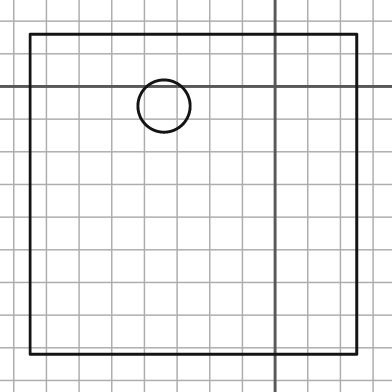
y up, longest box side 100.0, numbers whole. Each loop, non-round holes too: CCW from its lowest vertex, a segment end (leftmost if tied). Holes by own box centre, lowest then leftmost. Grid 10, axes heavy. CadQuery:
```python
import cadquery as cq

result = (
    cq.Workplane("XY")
    .moveTo(-75.0, -82.0)
    .lineTo(25.0, -82.0)
    .lineTo(25.0, 16.0)
    .lineTo(-75.0, 16.0)
    .close()
    .moveTo(-34.0, -6.0)
    .circle(8.0)
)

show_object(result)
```